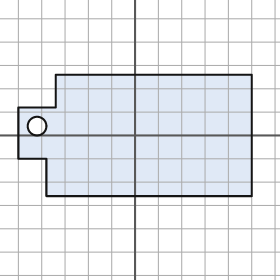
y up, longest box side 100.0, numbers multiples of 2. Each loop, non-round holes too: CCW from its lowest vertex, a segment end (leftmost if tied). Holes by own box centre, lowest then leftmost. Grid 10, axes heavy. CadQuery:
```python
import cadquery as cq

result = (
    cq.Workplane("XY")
    .moveTo(-38.0, -26.0)
    .lineTo(50.0, -26.0)
    .lineTo(50.0, 26.0)
    .lineTo(-34.0, 26.0)
    .lineTo(-34.0, 12.0)
    .lineTo(-50.0, 12.0)
    .lineTo(-50.0, -10.0)
    .lineTo(-38.0, -10.0)
    .close()
    .moveTo(-42.0, 4.0)
    .circle(4.0)
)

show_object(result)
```